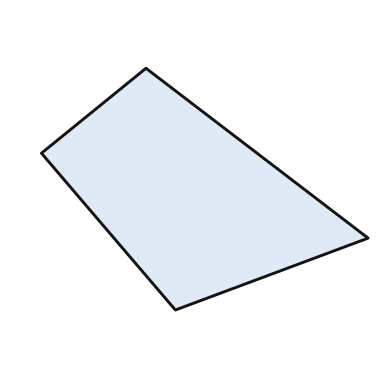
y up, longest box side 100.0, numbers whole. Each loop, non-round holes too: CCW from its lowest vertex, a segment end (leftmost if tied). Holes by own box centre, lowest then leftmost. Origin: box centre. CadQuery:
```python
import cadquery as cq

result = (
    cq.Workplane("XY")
    .moveTo(-9.0, -37.0)
    .lineTo(50.0, -15.0)
    .lineTo(-18.0, 37.0)
    .lineTo(-50.0, 11.0)
    .close()
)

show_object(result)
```